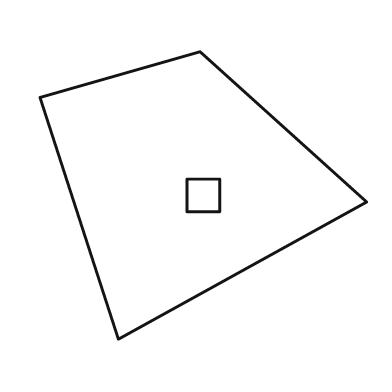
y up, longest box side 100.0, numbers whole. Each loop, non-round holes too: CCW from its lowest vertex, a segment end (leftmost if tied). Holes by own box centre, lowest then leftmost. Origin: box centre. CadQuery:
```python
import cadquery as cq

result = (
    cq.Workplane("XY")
    .moveTo(-26.0, -44.0)
    .lineTo(50.0, -2.0)
    .lineTo(-1.0, 44.0)
    .lineTo(-50.0, 30.0)
    .close()
    .moveTo(-5.0, -5.0)
    .lineTo(5.0, -5.0)
    .lineTo(5.0, 5.0)
    .lineTo(-5.0, 5.0)
    .close()
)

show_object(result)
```